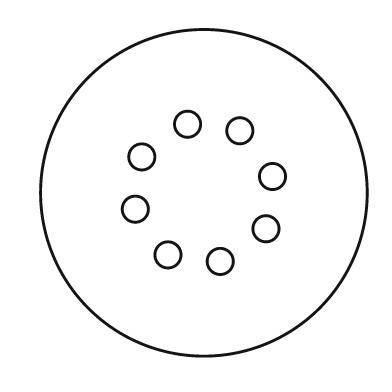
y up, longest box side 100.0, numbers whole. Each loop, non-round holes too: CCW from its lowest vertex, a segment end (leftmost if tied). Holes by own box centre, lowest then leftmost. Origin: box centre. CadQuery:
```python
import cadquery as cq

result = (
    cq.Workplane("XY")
    .moveTo(0.0, 0.0)
    .circle(50.0)
    .moveTo(5.0, -21.0)
    .circle(4.0)
    .moveTo(-11.0, -19.0)
    .circle(4.0)
    .moveTo(19.0, -11.0)
    .circle(4.0)
    .moveTo(-21.0, -5.0)
    .circle(4.0)
    .moveTo(21.0, 5.0)
    .circle(4.0)
    .moveTo(-19.0, 11.0)
    .circle(4.0)
    .moveTo(11.0, 19.0)
    .circle(4.0)
    .moveTo(-5.0, 21.0)
    .circle(4.0)
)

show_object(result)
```